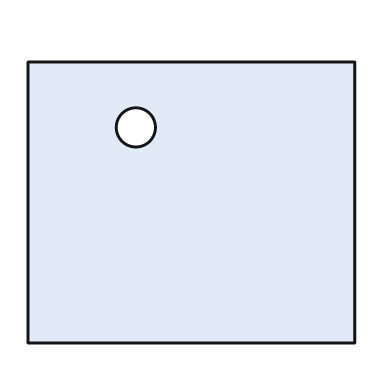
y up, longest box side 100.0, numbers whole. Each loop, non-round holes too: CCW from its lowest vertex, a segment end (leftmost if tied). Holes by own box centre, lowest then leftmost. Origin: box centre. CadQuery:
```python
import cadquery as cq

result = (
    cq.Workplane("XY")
    .moveTo(-50.0, -43.0)
    .lineTo(50.0, -43.0)
    .lineTo(50.0, 43.0)
    .lineTo(-50.0, 43.0)
    .close()
    .moveTo(-17.0, 23.0)
    .circle(6.0)
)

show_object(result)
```